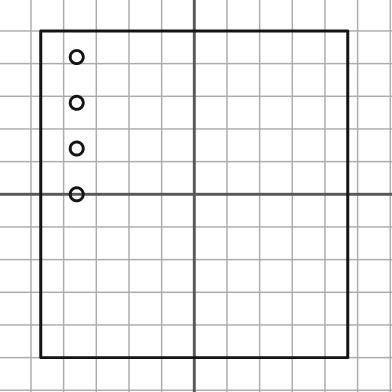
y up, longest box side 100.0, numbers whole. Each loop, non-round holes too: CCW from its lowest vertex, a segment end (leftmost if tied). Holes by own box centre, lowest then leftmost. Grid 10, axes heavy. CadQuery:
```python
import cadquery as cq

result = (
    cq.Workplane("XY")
    .moveTo(-47.0, -50.0)
    .lineTo(47.0, -50.0)
    .lineTo(47.0, 50.0)
    .lineTo(-47.0, 50.0)
    .close()
    .moveTo(-36.0, 0.0)
    .circle(2.0)
    .moveTo(-36.0, 14.0)
    .circle(2.0)
    .moveTo(-36.0, 28.0)
    .circle(2.0)
    .moveTo(-36.0, 42.0)
    .circle(2.0)
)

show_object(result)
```